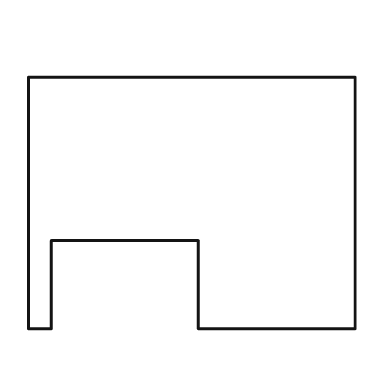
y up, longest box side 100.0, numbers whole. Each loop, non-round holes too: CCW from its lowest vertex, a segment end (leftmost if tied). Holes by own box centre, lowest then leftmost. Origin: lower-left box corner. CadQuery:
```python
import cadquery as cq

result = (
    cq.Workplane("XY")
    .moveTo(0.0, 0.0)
    .lineTo(7.0, 0.0)
    .lineTo(7.0, 27.0)
    .lineTo(52.0, 27.0)
    .lineTo(52.0, 0.0)
    .lineTo(100.0, 0.0)
    .lineTo(100.0, 77.0)
    .lineTo(0.0, 77.0)
    .close()
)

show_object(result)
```